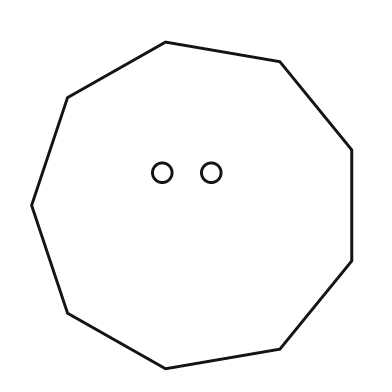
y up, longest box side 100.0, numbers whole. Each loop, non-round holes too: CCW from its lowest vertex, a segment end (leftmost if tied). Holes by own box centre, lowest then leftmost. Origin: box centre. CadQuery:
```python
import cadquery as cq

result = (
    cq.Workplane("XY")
    .moveTo(-8.0, -50.0)
    .lineTo(27.0, -44.0)
    .lineTo(49.0, -17.0)
    .lineTo(49.0, 17.0)
    .lineTo(27.0, 44.0)
    .lineTo(-8.0, 50.0)
    .lineTo(-38.0, 33.0)
    .lineTo(-49.0, 0.0)
    .lineTo(-38.0, -33.0)
    .close()
    .moveTo(-9.0, 10.0)
    .circle(3.0)
    .moveTo(6.0, 10.0)
    .circle(3.0)
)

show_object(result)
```